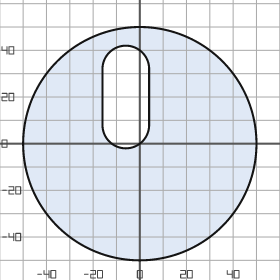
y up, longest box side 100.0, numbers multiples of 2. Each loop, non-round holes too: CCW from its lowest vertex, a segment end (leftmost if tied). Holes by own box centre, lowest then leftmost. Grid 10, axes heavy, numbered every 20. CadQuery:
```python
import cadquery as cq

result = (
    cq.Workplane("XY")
    .moveTo(0.0, 0.0)
    .circle(50.0)
    .moveTo(-16.0, 8.0)
    .threePointArc((-6.0, -2.0), (4.0, 8.0))
    .lineTo(4.0, 32.0)
    .threePointArc((-6.0, 42.0), (-16.0, 32.0))
    .close()
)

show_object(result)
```